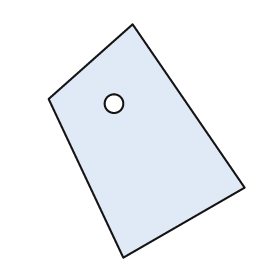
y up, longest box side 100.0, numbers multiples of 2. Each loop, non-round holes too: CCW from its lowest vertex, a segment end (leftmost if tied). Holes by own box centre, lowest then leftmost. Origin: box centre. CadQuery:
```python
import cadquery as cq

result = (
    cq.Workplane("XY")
    .moveTo(-10.0, -50.0)
    .lineTo(42.0, -20.0)
    .lineTo(-6.0, 50.0)
    .lineTo(-42.0, 18.0)
    .close()
    .moveTo(-14.0, 16.0)
    .circle(4.0)
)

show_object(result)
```